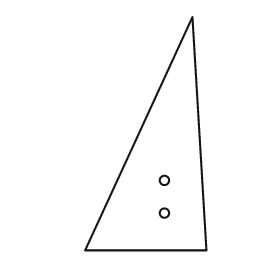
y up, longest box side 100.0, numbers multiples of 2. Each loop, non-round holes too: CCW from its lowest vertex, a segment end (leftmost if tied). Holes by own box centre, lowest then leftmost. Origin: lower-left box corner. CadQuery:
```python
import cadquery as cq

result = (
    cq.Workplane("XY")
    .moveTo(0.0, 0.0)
    .lineTo(52.0, 0.0)
    .lineTo(46.0, 100.0)
    .close()
    .moveTo(34.0, 16.0)
    .circle(2.0)
    .moveTo(34.0, 30.0)
    .circle(2.0)
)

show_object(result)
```